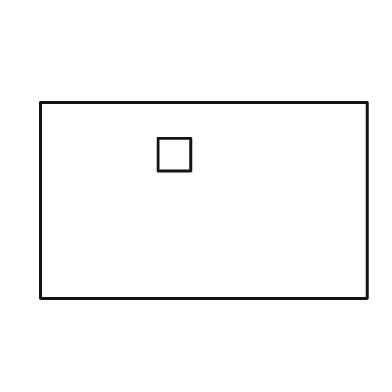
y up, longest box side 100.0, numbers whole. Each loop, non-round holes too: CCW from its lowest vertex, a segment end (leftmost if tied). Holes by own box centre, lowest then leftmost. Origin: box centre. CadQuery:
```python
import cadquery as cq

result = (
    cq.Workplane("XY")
    .moveTo(-50.0, -30.0)
    .lineTo(50.0, -30.0)
    .lineTo(50.0, 30.0)
    .lineTo(-50.0, 30.0)
    .close()
    .moveTo(-14.0, 9.0)
    .lineTo(-4.0, 9.0)
    .lineTo(-4.0, 19.0)
    .lineTo(-14.0, 19.0)
    .close()
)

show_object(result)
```